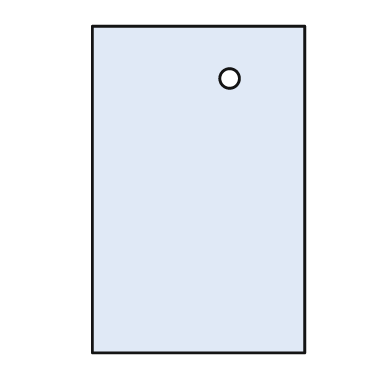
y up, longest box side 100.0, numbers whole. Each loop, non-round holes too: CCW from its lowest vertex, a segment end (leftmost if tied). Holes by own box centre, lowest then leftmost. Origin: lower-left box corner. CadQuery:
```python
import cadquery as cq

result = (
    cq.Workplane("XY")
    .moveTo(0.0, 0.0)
    .lineTo(65.0, 0.0)
    .lineTo(65.0, 100.0)
    .lineTo(0.0, 100.0)
    .close()
    .moveTo(42.0, 84.0)
    .circle(3.0)
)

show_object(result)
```